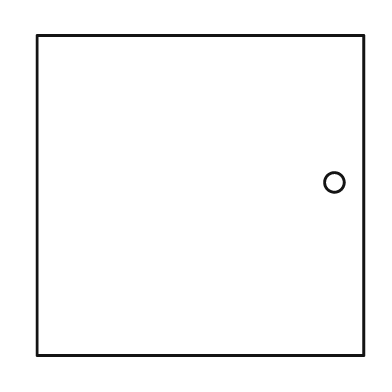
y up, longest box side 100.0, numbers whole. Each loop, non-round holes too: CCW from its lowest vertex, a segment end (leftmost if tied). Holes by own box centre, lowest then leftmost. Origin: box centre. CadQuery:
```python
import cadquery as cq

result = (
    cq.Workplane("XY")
    .moveTo(-50.0, -49.0)
    .lineTo(50.0, -49.0)
    .lineTo(50.0, 49.0)
    .lineTo(-50.0, 49.0)
    .close()
    .moveTo(41.0, 4.0)
    .circle(3.0)
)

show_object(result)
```